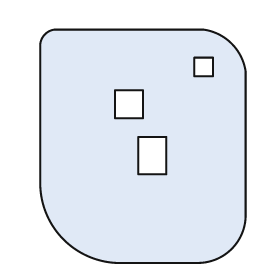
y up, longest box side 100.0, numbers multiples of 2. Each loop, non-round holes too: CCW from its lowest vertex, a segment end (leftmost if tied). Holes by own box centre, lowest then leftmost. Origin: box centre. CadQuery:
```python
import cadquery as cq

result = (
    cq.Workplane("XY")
    .moveTo(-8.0, -50.0)
    .lineTo(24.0, -50.0)
    .threePointArc((38.0, -44.0), (44.0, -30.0))
    .lineTo(44.0, 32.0)
    .threePointArc((38.0, 44.0), (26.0, 50.0))
    .lineTo(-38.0, 50.0)
    .threePointArc((-42.0, 48.0), (-44.0, 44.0))
    .lineTo(-44.0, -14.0)
    .threePointArc((-34.0, -40.0), (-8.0, -50.0))
    .close()
    .moveTo(-2.0, -12.0)
    .lineTo(10.0, -12.0)
    .lineTo(10.0, 4.0)
    .lineTo(-2.0, 4.0)
    .close()
    .moveTo(-12.0, 12.0)
    .lineTo(0.0, 12.0)
    .lineTo(0.0, 24.0)
    .lineTo(-12.0, 24.0)
    .close()
    .moveTo(22.0, 30.0)
    .lineTo(30.0, 30.0)
    .lineTo(30.0, 38.0)
    .lineTo(22.0, 38.0)
    .close()
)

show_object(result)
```